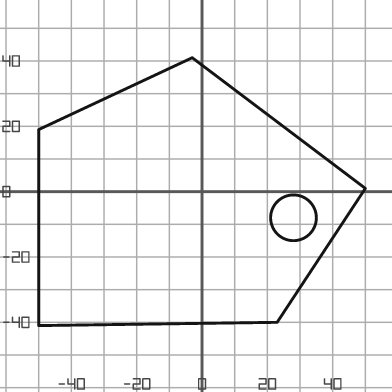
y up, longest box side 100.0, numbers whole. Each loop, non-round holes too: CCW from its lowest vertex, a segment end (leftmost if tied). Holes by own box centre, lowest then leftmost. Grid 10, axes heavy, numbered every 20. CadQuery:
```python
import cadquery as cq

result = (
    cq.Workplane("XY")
    .moveTo(-50.0, -41.0)
    .lineTo(23.0, -40.0)
    .lineTo(50.0, 1.0)
    .lineTo(-3.0, 41.0)
    .lineTo(-50.0, 19.0)
    .close()
    .moveTo(28.0, -8.0)
    .circle(7.0)
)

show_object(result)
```